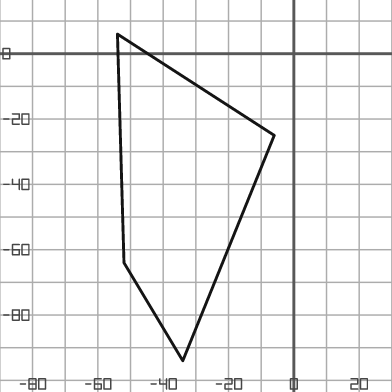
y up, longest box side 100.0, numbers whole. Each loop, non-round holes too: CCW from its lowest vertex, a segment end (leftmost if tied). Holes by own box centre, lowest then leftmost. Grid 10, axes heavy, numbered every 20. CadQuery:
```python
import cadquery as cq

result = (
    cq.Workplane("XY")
    .moveTo(-34.0, -94.0)
    .lineTo(-6.0, -25.0)
    .lineTo(-54.0, 6.0)
    .lineTo(-52.0, -64.0)
    .close()
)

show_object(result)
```